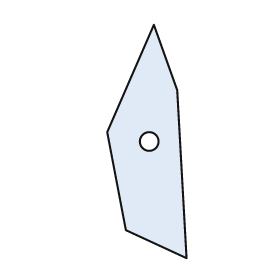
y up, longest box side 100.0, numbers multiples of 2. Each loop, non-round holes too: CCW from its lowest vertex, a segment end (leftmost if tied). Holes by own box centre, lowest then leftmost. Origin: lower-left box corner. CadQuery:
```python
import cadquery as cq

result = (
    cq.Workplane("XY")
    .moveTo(34.0, 0.0)
    .lineTo(30.0, 72.0)
    .lineTo(20.0, 100.0)
    .lineTo(0.0, 54.0)
    .lineTo(8.0, 12.0)
    .close()
    .moveTo(18.0, 50.0)
    .circle(4.0)
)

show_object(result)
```